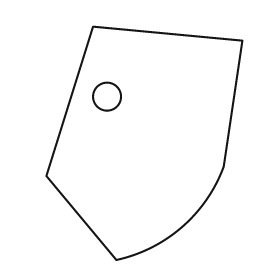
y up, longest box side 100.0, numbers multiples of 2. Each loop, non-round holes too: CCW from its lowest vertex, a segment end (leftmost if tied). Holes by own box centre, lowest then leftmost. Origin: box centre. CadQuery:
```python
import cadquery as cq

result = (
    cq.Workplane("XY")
    .moveTo(-12.0, -50.0)
    .threePointArc((16.0, -36.0), (34.0, -10.0))
    .lineTo(42.0, 44.0)
    .lineTo(-22.0, 50.0)
    .lineTo(-42.0, -14.0)
    .close()
    .moveTo(-16.0, 20.0)
    .circle(6.0)
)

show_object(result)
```